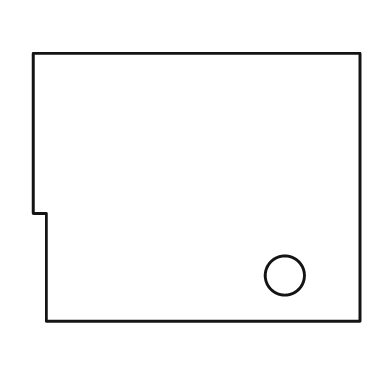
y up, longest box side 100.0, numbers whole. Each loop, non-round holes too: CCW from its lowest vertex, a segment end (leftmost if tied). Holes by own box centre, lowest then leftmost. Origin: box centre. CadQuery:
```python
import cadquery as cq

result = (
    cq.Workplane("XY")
    .moveTo(-46.0, -41.0)
    .lineTo(50.0, -41.0)
    .lineTo(50.0, 41.0)
    .lineTo(-50.0, 41.0)
    .lineTo(-50.0, -8.0)
    .lineTo(-46.0, -8.0)
    .close()
    .moveTo(27.0, -27.0)
    .circle(6.0)
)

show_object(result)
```